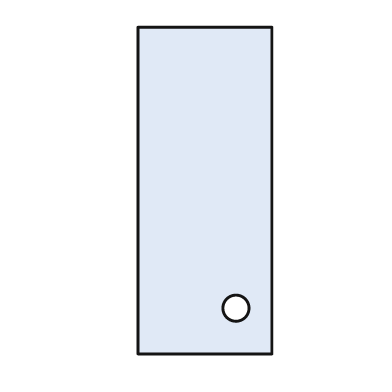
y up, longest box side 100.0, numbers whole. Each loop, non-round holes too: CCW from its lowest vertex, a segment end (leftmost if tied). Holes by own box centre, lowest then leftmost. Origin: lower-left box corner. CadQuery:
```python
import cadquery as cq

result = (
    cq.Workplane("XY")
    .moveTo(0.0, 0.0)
    .lineTo(41.0, 0.0)
    .lineTo(41.0, 100.0)
    .lineTo(0.0, 100.0)
    .close()
    .moveTo(30.0, 14.0)
    .circle(4.0)
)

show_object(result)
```